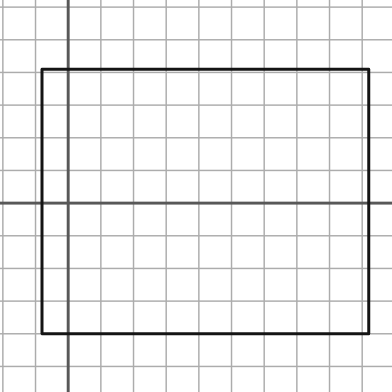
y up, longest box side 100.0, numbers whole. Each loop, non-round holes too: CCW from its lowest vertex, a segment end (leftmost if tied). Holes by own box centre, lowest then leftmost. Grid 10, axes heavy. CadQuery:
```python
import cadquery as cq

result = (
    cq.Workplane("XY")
    .moveTo(-8.0, -40.0)
    .lineTo(92.0, -40.0)
    .lineTo(92.0, 41.0)
    .lineTo(-8.0, 41.0)
    .close()
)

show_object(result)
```